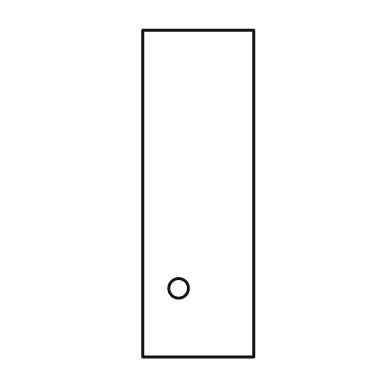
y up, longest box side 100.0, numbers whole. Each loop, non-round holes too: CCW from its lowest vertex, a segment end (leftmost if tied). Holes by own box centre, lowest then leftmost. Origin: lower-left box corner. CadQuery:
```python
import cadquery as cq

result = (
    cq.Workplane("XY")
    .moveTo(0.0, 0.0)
    .lineTo(34.0, 0.0)
    .lineTo(34.0, 100.0)
    .lineTo(0.0, 100.0)
    .close()
    .moveTo(11.0, 21.0)
    .circle(3.0)
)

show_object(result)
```